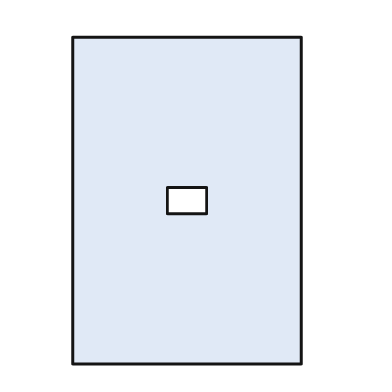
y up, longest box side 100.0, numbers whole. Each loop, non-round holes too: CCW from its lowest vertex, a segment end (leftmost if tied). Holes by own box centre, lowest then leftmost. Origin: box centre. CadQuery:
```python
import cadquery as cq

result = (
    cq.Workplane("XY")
    .moveTo(-35.0, -50.0)
    .lineTo(35.0, -50.0)
    .lineTo(35.0, 50.0)
    .lineTo(-35.0, 50.0)
    .close()
    .moveTo(-6.0, -4.0)
    .lineTo(6.0, -4.0)
    .lineTo(6.0, 4.0)
    .lineTo(-6.0, 4.0)
    .close()
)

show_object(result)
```